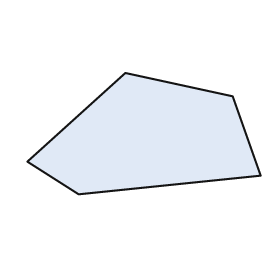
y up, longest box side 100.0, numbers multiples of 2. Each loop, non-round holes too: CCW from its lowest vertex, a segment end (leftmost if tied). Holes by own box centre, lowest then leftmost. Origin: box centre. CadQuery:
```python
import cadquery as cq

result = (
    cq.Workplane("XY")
    .moveTo(-28.0, -26.0)
    .lineTo(50.0, -18.0)
    .lineTo(38.0, 16.0)
    .lineTo(-8.0, 26.0)
    .lineTo(-50.0, -12.0)
    .close()
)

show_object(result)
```